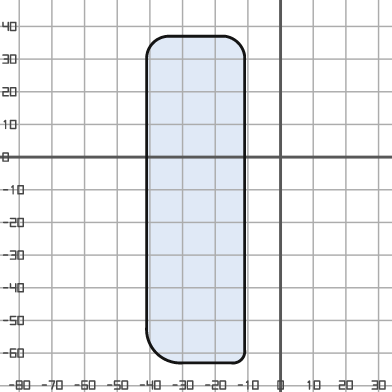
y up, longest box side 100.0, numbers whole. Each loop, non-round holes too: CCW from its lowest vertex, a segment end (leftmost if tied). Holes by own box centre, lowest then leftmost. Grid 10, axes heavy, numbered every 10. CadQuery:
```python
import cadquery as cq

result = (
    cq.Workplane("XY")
    .moveTo(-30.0, -63.0)
    .lineTo(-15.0, -63.0)
    .threePointArc((-12.0, -62.0), (-11.0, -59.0))
    .lineTo(-11.0, 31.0)
    .threePointArc((-13.0, 35.0), (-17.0, 37.0))
    .lineTo(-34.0, 37.0)
    .threePointArc((-39.0, 35.0), (-41.0, 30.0))
    .lineTo(-41.0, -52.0)
    .threePointArc((-38.0, -60.0), (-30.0, -63.0))
    .close()
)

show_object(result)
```